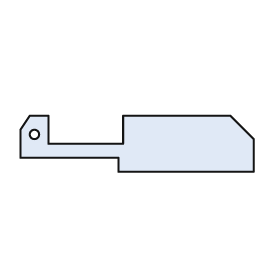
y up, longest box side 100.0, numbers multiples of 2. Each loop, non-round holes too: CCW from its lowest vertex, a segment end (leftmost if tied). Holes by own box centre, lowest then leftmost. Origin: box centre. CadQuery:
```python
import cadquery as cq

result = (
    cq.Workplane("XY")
    .moveTo(-8.0, -12.0)
    .lineTo(50.0, -12.0)
    .lineTo(50.0, 2.0)
    .lineTo(40.0, 12.0)
    .lineTo(-6.0, 12.0)
    .lineTo(-6.0, 0.0)
    .lineTo(-38.0, 0.0)
    .lineTo(-38.0, 12.0)
    .lineTo(-46.0, 12.0)
    .lineTo(-50.0, 6.0)
    .lineTo(-50.0, -6.0)
    .lineTo(-8.0, -6.0)
    .close()
    .moveTo(-44.0, 4.0)
    .circle(2.0)
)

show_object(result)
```